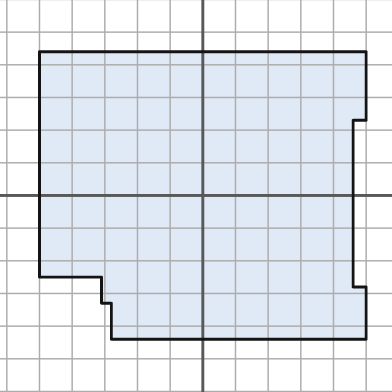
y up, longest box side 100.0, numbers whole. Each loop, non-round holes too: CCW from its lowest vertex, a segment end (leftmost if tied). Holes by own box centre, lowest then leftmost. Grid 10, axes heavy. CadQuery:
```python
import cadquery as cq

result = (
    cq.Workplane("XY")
    .moveTo(-28.0, -44.0)
    .lineTo(50.0, -44.0)
    .lineTo(50.0, -28.0)
    .lineTo(46.0, -28.0)
    .lineTo(46.0, 23.0)
    .lineTo(50.0, 23.0)
    .lineTo(50.0, 44.0)
    .lineTo(-50.0, 44.0)
    .lineTo(-50.0, -25.0)
    .lineTo(-31.0, -25.0)
    .lineTo(-31.0, -33.0)
    .lineTo(-28.0, -33.0)
    .close()
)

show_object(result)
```